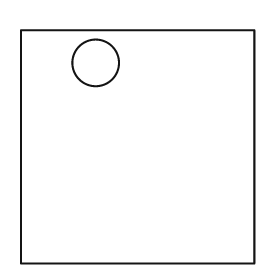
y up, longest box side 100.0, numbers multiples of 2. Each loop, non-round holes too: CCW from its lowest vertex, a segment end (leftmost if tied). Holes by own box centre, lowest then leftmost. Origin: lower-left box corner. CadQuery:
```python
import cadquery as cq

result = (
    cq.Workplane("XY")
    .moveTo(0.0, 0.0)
    .lineTo(100.0, 0.0)
    .lineTo(100.0, 100.0)
    .lineTo(0.0, 100.0)
    .close()
    .moveTo(32.0, 86.0)
    .circle(10.0)
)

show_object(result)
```